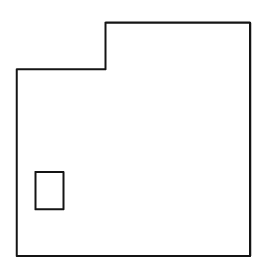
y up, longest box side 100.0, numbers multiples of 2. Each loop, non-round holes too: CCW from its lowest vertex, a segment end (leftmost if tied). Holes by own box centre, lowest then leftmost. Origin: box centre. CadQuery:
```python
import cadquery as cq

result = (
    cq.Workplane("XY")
    .moveTo(-50.0, -50.0)
    .lineTo(50.0, -50.0)
    .lineTo(50.0, 50.0)
    .lineTo(-12.0, 50.0)
    .lineTo(-12.0, 30.0)
    .lineTo(-50.0, 30.0)
    .close()
    .moveTo(-42.0, -30.0)
    .lineTo(-30.0, -30.0)
    .lineTo(-30.0, -14.0)
    .lineTo(-42.0, -14.0)
    .close()
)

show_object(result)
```